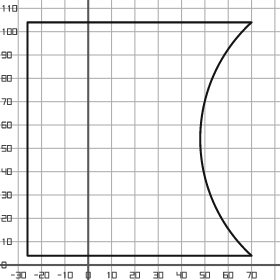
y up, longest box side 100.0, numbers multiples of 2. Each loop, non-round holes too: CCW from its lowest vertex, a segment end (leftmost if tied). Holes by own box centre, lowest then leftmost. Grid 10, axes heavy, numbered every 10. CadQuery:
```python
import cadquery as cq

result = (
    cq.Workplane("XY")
    .moveTo(-26.0, 4.0)
    .lineTo(70.0, 4.0)
    .threePointArc((48.0, 54.0), (70.0, 104.0))
    .lineTo(-26.0, 104.0)
    .close()
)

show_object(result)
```